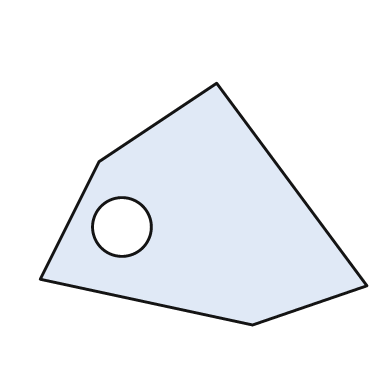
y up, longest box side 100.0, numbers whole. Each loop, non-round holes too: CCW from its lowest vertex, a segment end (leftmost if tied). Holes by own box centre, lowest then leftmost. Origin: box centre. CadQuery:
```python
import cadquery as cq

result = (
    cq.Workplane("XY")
    .moveTo(15.0, -37.0)
    .lineTo(50.0, -25.0)
    .lineTo(4.0, 37.0)
    .lineTo(-32.0, 13.0)
    .lineTo(-50.0, -23.0)
    .close()
    .moveTo(-25.0, -7.0)
    .circle(9.0)
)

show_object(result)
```